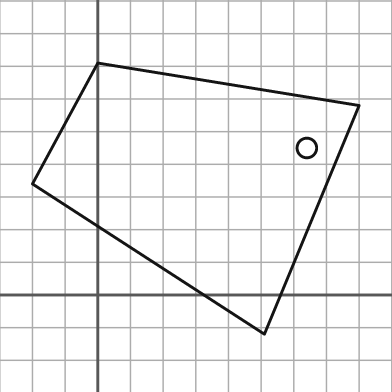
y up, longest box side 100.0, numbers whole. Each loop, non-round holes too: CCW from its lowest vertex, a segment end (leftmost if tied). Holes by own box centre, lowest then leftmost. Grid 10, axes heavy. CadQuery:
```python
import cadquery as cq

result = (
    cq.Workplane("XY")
    .moveTo(51.0, -12.0)
    .lineTo(80.0, 58.0)
    .lineTo(0.0, 71.0)
    .lineTo(-20.0, 34.0)
    .close()
    .moveTo(64.0, 45.0)
    .circle(3.0)
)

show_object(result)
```